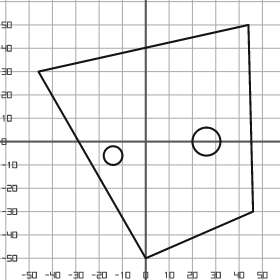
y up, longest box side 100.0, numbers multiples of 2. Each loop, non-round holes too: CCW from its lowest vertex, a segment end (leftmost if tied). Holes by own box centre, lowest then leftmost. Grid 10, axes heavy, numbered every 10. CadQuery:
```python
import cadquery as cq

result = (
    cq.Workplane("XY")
    .moveTo(0.0, -50.0)
    .lineTo(46.0, -30.0)
    .lineTo(44.0, 50.0)
    .lineTo(-46.0, 30.0)
    .close()
    .moveTo(-14.0, -6.0)
    .circle(4.0)
    .moveTo(26.0, 0.0)
    .circle(6.0)
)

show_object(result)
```